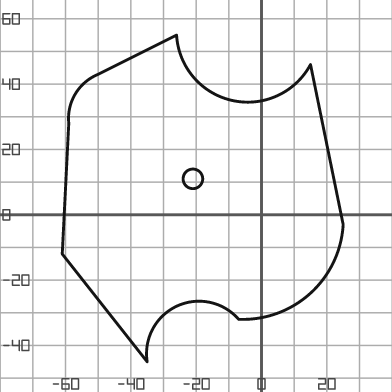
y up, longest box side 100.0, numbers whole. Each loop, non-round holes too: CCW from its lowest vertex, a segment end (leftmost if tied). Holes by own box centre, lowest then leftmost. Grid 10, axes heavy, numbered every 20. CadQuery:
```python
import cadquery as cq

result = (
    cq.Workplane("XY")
    .moveTo(-35.0, -45.0)
    .threePointArc((-26.0, -28.0), (-7.0, -32.0))
    .threePointArc((15.0, -24.0), (25.0, -3.0))
    .lineTo(15.0, 46.0)
    .threePointArc((-9.0, 35.0), (-26.0, 55.0))
    .lineTo(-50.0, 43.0)
    .threePointArc((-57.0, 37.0), (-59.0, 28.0))
    .lineTo(-61.0, -12.0)
    .close()
    .moveTo(-21.0, 11.0)
    .circle(3.0)
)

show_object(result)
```